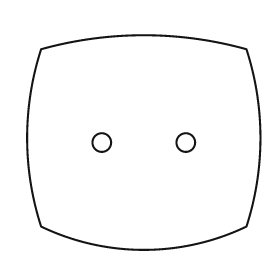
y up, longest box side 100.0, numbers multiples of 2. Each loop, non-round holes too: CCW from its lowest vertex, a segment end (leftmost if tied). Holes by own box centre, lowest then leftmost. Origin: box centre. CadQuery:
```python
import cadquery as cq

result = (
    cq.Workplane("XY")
    .moveTo(-44.0, -36.0)
    .threePointArc((0.0, -46.0), (44.0, -36.0))
    .threePointArc((50.0, 2.0), (44.0, 40.0))
    .threePointArc((0.0, 46.0), (-44.0, 40.0))
    .threePointArc((-50.0, 2.0), (-44.0, -36.0))
    .close()
    .moveTo(-18.0, 0.0)
    .circle(4.0)
    .moveTo(18.0, 0.0)
    .circle(4.0)
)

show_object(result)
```